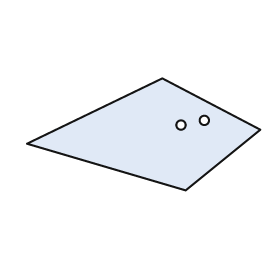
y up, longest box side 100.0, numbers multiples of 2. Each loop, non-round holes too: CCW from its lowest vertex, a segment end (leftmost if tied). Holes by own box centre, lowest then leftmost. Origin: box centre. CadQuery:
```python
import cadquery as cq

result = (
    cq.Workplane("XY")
    .moveTo(18.0, -24.0)
    .lineTo(50.0, 2.0)
    .lineTo(8.0, 24.0)
    .lineTo(-50.0, -4.0)
    .close()
    .moveTo(16.0, 4.0)
    .circle(2.0)
    .moveTo(26.0, 6.0)
    .circle(2.0)
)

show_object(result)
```